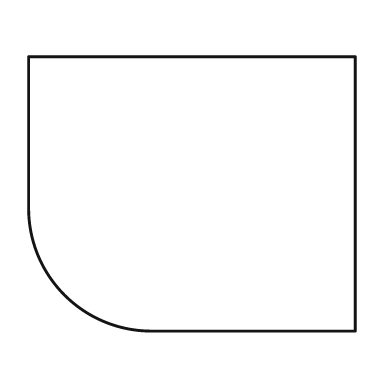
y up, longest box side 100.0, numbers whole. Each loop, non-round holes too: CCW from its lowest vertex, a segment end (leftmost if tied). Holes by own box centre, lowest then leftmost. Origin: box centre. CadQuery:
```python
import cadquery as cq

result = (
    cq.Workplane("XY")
    .moveTo(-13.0, -42.0)
    .lineTo(50.0, -42.0)
    .lineTo(50.0, 42.0)
    .lineTo(-50.0, 42.0)
    .lineTo(-50.0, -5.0)
    .threePointArc((-39.0, -31.0), (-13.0, -42.0))
    .close()
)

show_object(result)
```